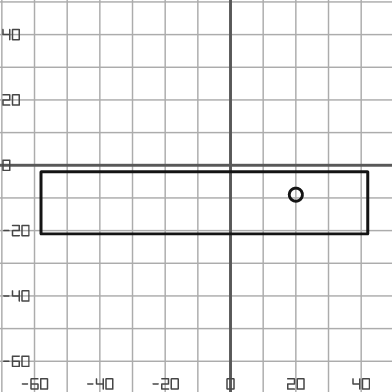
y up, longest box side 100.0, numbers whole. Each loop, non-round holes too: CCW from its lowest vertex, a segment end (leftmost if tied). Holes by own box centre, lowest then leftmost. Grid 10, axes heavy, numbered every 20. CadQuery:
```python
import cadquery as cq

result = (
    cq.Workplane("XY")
    .moveTo(-58.0, -21.0)
    .lineTo(42.0, -21.0)
    .lineTo(42.0, -2.0)
    .lineTo(-58.0, -2.0)
    .close()
    .moveTo(20.0, -9.0)
    .circle(2.0)
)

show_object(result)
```